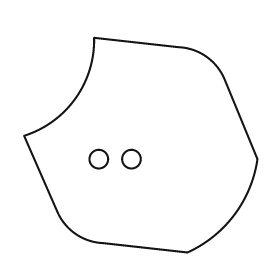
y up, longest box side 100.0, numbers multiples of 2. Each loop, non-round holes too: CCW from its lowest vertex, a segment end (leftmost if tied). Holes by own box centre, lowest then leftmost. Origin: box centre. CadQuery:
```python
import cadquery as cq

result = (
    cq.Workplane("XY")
    .moveTo(20.0, -46.0)
    .threePointArc((40.0, -30.0), (50.0, -6.0))
    .lineTo(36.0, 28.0)
    .threePointArc((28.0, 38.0), (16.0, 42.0))
    .lineTo(-20.0, 46.0)
    .threePointArc((-28.0, 20.0), (-50.0, 4.0))
    .lineTo(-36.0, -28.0)
    .threePointArc((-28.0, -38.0), (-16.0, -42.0))
    .close()
    .moveTo(-18.0, -6.0)
    .circle(4.0)
    .moveTo(-4.0, -6.0)
    .circle(4.0)
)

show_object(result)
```